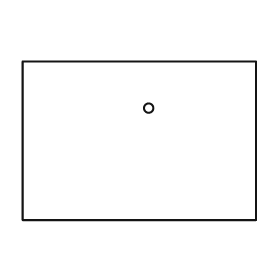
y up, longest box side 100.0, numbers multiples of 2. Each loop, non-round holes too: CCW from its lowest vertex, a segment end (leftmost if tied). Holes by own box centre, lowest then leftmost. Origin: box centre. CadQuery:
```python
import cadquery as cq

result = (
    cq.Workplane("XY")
    .moveTo(-50.0, -34.0)
    .lineTo(50.0, -34.0)
    .lineTo(50.0, 34.0)
    .lineTo(-50.0, 34.0)
    .close()
    .moveTo(4.0, 14.0)
    .circle(2.0)
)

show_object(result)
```